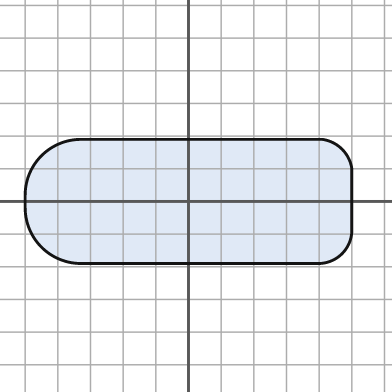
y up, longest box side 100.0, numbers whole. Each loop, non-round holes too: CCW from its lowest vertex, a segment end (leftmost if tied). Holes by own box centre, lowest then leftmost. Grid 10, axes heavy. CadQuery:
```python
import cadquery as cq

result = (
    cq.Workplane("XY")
    .moveTo(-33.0, -19.0)
    .lineTo(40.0, -19.0)
    .threePointArc((47.0, -16.0), (50.0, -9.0))
    .lineTo(50.0, 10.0)
    .threePointArc((47.0, 16.0), (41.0, 19.0))
    .lineTo(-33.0, 19.0)
    .threePointArc((-45.0, 14.0), (-50.0, 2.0))
    .lineTo(-50.0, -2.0)
    .threePointArc((-45.0, -14.0), (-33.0, -19.0))
    .close()
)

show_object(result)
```